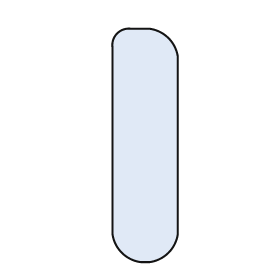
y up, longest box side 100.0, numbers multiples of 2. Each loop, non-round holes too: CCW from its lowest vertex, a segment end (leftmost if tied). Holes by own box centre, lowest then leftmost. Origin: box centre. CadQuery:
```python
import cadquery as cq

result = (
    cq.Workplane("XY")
    .moveTo(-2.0, -50.0)
    .lineTo(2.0, -50.0)
    .threePointArc((10.0, -46.0), (14.0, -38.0))
    .lineTo(14.0, 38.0)
    .threePointArc((10.0, 46.0), (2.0, 50.0))
    .lineTo(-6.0, 50.0)
    .threePointArc((-12.0, 48.0), (-14.0, 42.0))
    .lineTo(-14.0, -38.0)
    .threePointArc((-10.0, -46.0), (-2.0, -50.0))
    .close()
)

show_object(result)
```